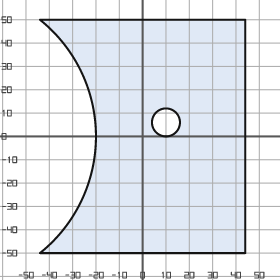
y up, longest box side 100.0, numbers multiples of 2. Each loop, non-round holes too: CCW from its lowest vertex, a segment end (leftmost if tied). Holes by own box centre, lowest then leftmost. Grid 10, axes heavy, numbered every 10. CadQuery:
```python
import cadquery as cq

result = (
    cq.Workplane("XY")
    .moveTo(-44.0, -50.0)
    .lineTo(44.0, -50.0)
    .lineTo(44.0, 50.0)
    .lineTo(-44.0, 50.0)
    .threePointArc((-20.0, 0.0), (-44.0, -50.0))
    .close()
    .moveTo(10.0, 6.0)
    .circle(6.0)
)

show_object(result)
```